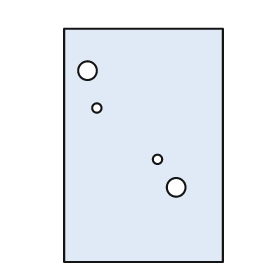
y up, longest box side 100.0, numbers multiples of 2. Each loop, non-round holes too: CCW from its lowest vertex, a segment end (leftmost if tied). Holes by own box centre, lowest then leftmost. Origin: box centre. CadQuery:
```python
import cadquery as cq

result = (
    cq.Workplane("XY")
    .moveTo(-34.0, -50.0)
    .lineTo(34.0, -50.0)
    .lineTo(34.0, 50.0)
    .lineTo(-34.0, 50.0)
    .close()
    .moveTo(14.0, -18.0)
    .circle(4.0)
    .moveTo(6.0, -6.0)
    .circle(2.0)
    .moveTo(-20.0, 16.0)
    .circle(2.0)
    .moveTo(-24.0, 32.0)
    .circle(4.0)
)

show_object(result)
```